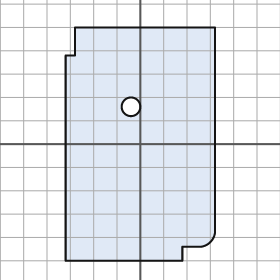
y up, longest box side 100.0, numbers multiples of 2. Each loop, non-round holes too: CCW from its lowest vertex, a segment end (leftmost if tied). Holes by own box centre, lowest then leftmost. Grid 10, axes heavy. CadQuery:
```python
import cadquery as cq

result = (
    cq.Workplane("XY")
    .moveTo(-32.0, -50.0)
    .lineTo(18.0, -50.0)
    .lineTo(18.0, -44.0)
    .lineTo(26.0, -44.0)
    .threePointArc((30.0, -42.0), (32.0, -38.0))
    .lineTo(32.0, 50.0)
    .lineTo(-28.0, 50.0)
    .lineTo(-28.0, 38.0)
    .lineTo(-32.0, 38.0)
    .close()
    .moveTo(-4.0, 16.0)
    .circle(4.0)
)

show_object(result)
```